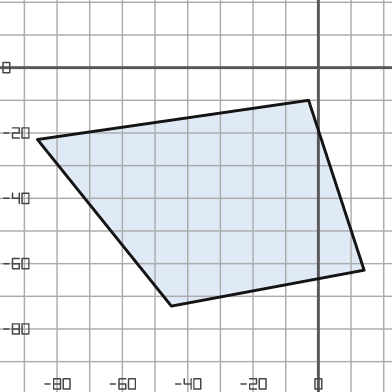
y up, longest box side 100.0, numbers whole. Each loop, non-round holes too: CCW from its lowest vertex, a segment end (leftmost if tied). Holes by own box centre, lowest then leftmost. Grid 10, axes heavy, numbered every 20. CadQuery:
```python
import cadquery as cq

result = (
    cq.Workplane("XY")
    .moveTo(-45.0, -73.0)
    .lineTo(14.0, -62.0)
    .lineTo(-3.0, -10.0)
    .lineTo(-86.0, -22.0)
    .close()
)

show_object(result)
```